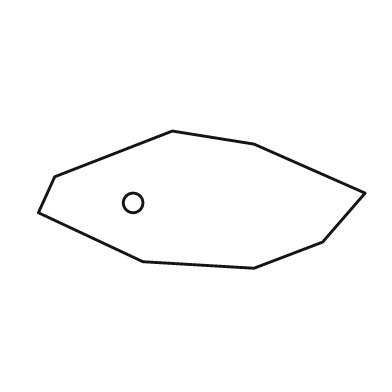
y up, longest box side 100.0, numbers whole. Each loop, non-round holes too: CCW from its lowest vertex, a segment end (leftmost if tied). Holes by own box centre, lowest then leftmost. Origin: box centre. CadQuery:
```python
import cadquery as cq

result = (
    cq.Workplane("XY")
    .moveTo(16.0, -21.0)
    .lineTo(37.0, -13.0)
    .lineTo(50.0, 2.0)
    .lineTo(16.0, 17.0)
    .lineTo(-9.0, 21.0)
    .lineTo(-45.0, 7.0)
    .lineTo(-50.0, -4.0)
    .lineTo(-18.0, -19.0)
    .close()
    .moveTo(-21.0, -1.0)
    .circle(3.0)
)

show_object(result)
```